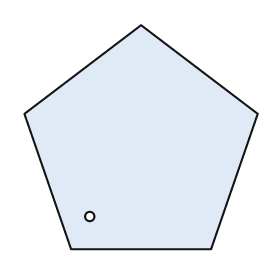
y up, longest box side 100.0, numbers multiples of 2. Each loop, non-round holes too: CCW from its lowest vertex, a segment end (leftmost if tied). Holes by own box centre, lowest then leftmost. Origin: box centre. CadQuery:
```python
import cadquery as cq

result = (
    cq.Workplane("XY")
    .moveTo(-30.0, -48.0)
    .lineTo(30.0, -48.0)
    .lineTo(50.0, 10.0)
    .lineTo(0.0, 48.0)
    .lineTo(-50.0, 10.0)
    .close()
    .moveTo(-22.0, -34.0)
    .circle(2.0)
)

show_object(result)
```